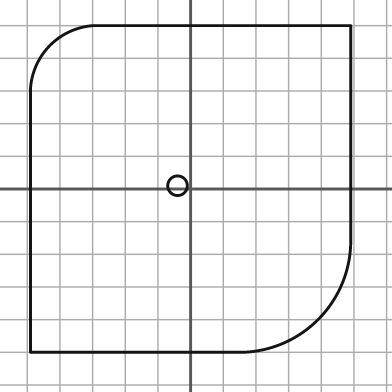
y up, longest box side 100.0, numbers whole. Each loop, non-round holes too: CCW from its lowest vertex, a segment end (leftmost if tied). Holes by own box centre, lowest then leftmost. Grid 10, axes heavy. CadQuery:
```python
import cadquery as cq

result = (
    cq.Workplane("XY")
    .moveTo(-49.0, -50.0)
    .lineTo(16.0, -50.0)
    .threePointArc((39.0, -40.0), (49.0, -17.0))
    .lineTo(49.0, 50.0)
    .lineTo(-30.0, 50.0)
    .threePointArc((-43.0, 44.0), (-49.0, 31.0))
    .close()
    .moveTo(-4.0, 1.0)
    .circle(3.0)
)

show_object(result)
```